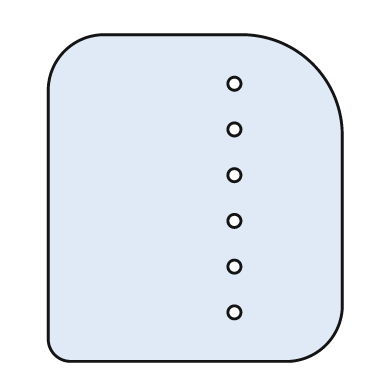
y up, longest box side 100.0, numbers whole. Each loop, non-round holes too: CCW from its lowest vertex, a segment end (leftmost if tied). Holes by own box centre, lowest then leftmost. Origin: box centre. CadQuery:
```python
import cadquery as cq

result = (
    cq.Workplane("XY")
    .moveTo(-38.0, -50.0)
    .lineTo(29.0, -50.0)
    .threePointArc((40.0, -45.0), (45.0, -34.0))
    .lineTo(45.0, 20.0)
    .threePointArc((36.0, 41.0), (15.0, 50.0))
    .lineTo(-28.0, 50.0)
    .threePointArc((-40.0, 45.0), (-45.0, 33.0))
    .lineTo(-45.0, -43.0)
    .threePointArc((-43.0, -48.0), (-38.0, -50.0))
    .close()
    .moveTo(12.0, -35.0)
    .circle(2.0)
    .moveTo(12.0, -21.0)
    .circle(2.0)
    .moveTo(12.0, -7.0)
    .circle(2.0)
    .moveTo(12.0, 7.0)
    .circle(2.0)
    .moveTo(12.0, 21.0)
    .circle(2.0)
    .moveTo(12.0, 35.0)
    .circle(2.0)
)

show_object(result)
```